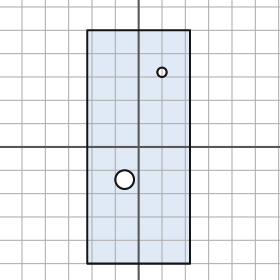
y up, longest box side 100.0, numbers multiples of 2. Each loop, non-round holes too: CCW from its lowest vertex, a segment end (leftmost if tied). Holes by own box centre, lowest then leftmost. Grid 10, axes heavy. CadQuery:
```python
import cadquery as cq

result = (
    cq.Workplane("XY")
    .moveTo(-22.0, -50.0)
    .lineTo(22.0, -50.0)
    .lineTo(22.0, 50.0)
    .lineTo(-22.0, 50.0)
    .close()
    .moveTo(-6.0, -14.0)
    .circle(4.0)
    .moveTo(10.0, 32.0)
    .circle(2.0)
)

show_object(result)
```